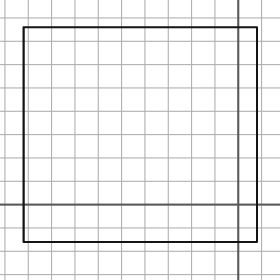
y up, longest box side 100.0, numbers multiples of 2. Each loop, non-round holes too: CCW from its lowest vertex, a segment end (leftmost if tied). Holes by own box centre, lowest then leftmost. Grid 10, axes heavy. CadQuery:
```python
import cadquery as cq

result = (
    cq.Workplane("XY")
    .moveTo(-92.0, -16.0)
    .lineTo(8.0, -16.0)
    .lineTo(8.0, 76.0)
    .lineTo(-92.0, 76.0)
    .close()
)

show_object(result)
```